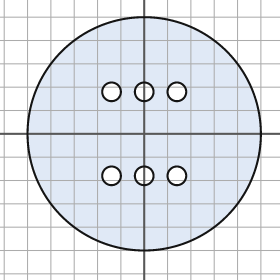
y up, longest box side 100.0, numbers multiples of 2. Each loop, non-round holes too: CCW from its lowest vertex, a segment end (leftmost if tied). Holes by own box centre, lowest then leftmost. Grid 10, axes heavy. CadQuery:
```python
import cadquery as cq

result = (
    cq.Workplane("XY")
    .moveTo(0.0, 0.0)
    .circle(50.0)
    .moveTo(-14.0, -18.0)
    .circle(4.0)
    .moveTo(0.0, -18.0)
    .circle(4.0)
    .moveTo(14.0, -18.0)
    .circle(4.0)
    .moveTo(-14.0, 18.0)
    .circle(4.0)
    .moveTo(0.0, 18.0)
    .circle(4.0)
    .moveTo(14.0, 18.0)
    .circle(4.0)
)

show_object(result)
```